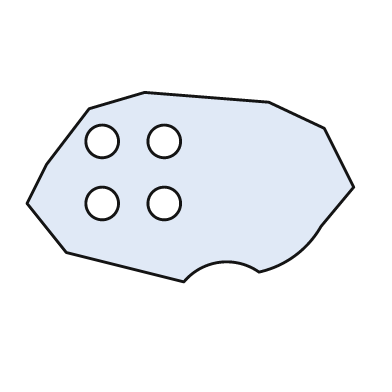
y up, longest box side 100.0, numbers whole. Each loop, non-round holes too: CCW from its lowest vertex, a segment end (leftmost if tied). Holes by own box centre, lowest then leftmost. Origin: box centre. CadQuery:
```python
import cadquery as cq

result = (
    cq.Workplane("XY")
    .moveTo(-2.0, -29.0)
    .threePointArc((9.0, -23.0), (21.0, -26.0))
    .threePointArc((32.0, -21.0), (40.0, -12.0))
    .lineTo(50.0, 0.0)
    .lineTo(41.0, 18.0)
    .lineTo(24.0, 26.0)
    .lineTo(-14.0, 29.0)
    .lineTo(-31.0, 24.0)
    .lineTo(-44.0, 7.0)
    .lineTo(-50.0, -5.0)
    .lineTo(-38.0, -20.0)
    .close()
    .moveTo(-27.0, -5.0)
    .circle(5.0)
    .moveTo(-8.0, -5.0)
    .circle(5.0)
    .moveTo(-27.0, 14.0)
    .circle(5.0)
    .moveTo(-8.0, 14.0)
    .circle(5.0)
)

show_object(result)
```